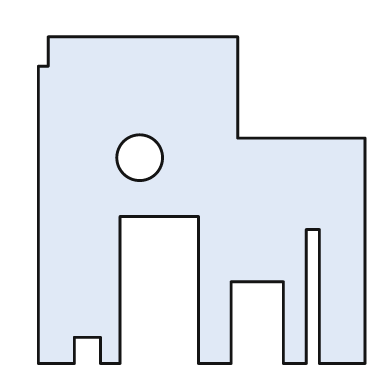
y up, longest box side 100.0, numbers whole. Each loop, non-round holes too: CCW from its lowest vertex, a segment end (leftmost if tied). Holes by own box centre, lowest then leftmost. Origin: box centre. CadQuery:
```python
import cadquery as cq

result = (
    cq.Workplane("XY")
    .moveTo(-50.0, -50.0)
    .lineTo(-39.0, -50.0)
    .lineTo(-39.0, -42.0)
    .lineTo(-31.0, -42.0)
    .lineTo(-31.0, -50.0)
    .lineTo(-25.0, -50.0)
    .lineTo(-25.0, -5.0)
    .lineTo(-1.0, -5.0)
    .lineTo(-1.0, -50.0)
    .lineTo(9.0, -50.0)
    .lineTo(9.0, -25.0)
    .lineTo(25.0, -25.0)
    .lineTo(25.0, -50.0)
    .lineTo(32.0, -50.0)
    .lineTo(32.0, -9.0)
    .lineTo(36.0, -9.0)
    .lineTo(36.0, -50.0)
    .lineTo(50.0, -50.0)
    .lineTo(50.0, 19.0)
    .lineTo(11.0, 19.0)
    .lineTo(11.0, 50.0)
    .lineTo(-47.0, 50.0)
    .lineTo(-47.0, 41.0)
    .lineTo(-50.0, 41.0)
    .close()
    .moveTo(-19.0, 13.0)
    .circle(7.0)
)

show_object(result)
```